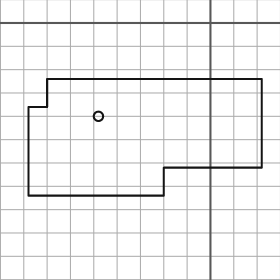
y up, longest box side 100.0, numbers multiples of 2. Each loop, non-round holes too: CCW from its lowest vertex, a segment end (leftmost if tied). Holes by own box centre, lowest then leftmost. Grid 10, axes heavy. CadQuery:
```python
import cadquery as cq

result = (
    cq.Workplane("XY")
    .moveTo(-78.0, -74.0)
    .lineTo(-20.0, -74.0)
    .lineTo(-20.0, -62.0)
    .lineTo(22.0, -62.0)
    .lineTo(22.0, -24.0)
    .lineTo(-70.0, -24.0)
    .lineTo(-70.0, -36.0)
    .lineTo(-78.0, -36.0)
    .close()
    .moveTo(-48.0, -40.0)
    .circle(2.0)
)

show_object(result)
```